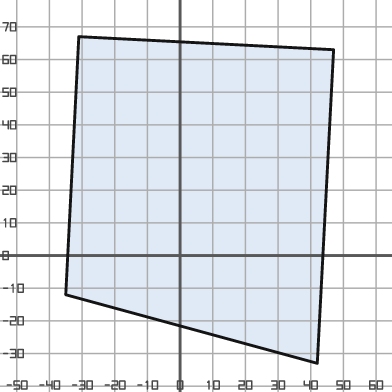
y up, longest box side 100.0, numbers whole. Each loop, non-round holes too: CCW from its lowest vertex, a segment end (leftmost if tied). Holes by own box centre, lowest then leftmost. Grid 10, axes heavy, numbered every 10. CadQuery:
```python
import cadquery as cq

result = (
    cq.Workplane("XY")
    .moveTo(42.0, -33.0)
    .lineTo(47.0, 63.0)
    .lineTo(-31.0, 67.0)
    .lineTo(-35.0, -12.0)
    .close()
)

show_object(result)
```